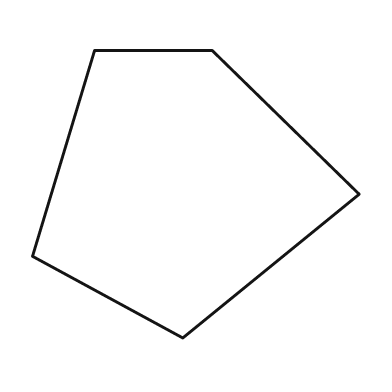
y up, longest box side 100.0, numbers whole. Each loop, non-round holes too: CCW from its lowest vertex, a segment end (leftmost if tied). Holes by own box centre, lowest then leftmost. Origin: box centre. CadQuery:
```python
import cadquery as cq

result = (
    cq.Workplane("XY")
    .moveTo(-4.0, -44.0)
    .lineTo(50.0, 0.0)
    .lineTo(5.0, 44.0)
    .lineTo(-31.0, 44.0)
    .lineTo(-50.0, -19.0)
    .close()
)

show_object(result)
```